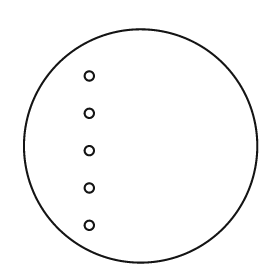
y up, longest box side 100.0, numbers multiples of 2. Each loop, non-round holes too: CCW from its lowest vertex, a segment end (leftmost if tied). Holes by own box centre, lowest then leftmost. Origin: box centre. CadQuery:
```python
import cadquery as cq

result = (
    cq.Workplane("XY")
    .moveTo(0.0, 0.0)
    .circle(50.0)
    .moveTo(-22.0, -34.0)
    .circle(2.0)
    .moveTo(-22.0, -18.0)
    .circle(2.0)
    .moveTo(-22.0, -2.0)
    .circle(2.0)
    .moveTo(-22.0, 14.0)
    .circle(2.0)
    .moveTo(-22.0, 30.0)
    .circle(2.0)
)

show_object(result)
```